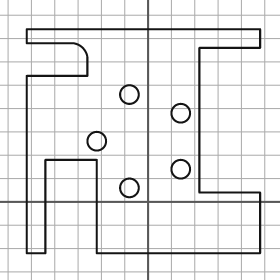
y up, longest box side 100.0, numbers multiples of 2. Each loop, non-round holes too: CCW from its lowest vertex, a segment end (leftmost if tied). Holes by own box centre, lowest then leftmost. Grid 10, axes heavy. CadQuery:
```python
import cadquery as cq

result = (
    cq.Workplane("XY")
    .moveTo(-52.0, -22.0)
    .lineTo(-44.0, -22.0)
    .lineTo(-44.0, 18.0)
    .lineTo(-22.0, 18.0)
    .lineTo(-22.0, -22.0)
    .lineTo(48.0, -22.0)
    .lineTo(48.0, 4.0)
    .lineTo(22.0, 4.0)
    .lineTo(22.0, 66.0)
    .lineTo(48.0, 66.0)
    .lineTo(48.0, 74.0)
    .lineTo(-52.0, 74.0)
    .lineTo(-52.0, 68.0)
    .lineTo(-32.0, 68.0)
    .threePointArc((-28.0, 66.0), (-26.0, 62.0))
    .lineTo(-26.0, 54.0)
    .lineTo(-52.0, 54.0)
    .close()
    .moveTo(-8.0, 6.0)
    .circle(4.0)
    .moveTo(14.0, 14.0)
    .circle(4.0)
    .moveTo(-22.0, 26.0)
    .circle(4.0)
    .moveTo(14.0, 38.0)
    .circle(4.0)
    .moveTo(-8.0, 46.0)
    .circle(4.0)
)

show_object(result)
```